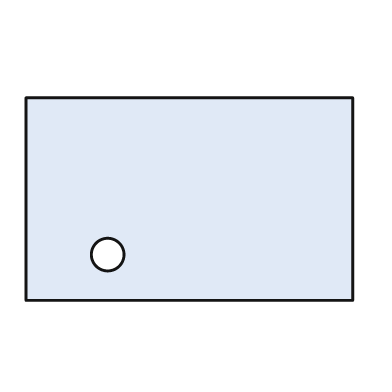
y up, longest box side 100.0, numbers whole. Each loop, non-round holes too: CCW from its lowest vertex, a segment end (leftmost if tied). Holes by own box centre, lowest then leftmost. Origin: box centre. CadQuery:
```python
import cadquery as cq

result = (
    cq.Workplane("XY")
    .moveTo(-50.0, -31.0)
    .lineTo(50.0, -31.0)
    .lineTo(50.0, 31.0)
    .lineTo(-50.0, 31.0)
    .close()
    .moveTo(-25.0, -17.0)
    .circle(5.0)
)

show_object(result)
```